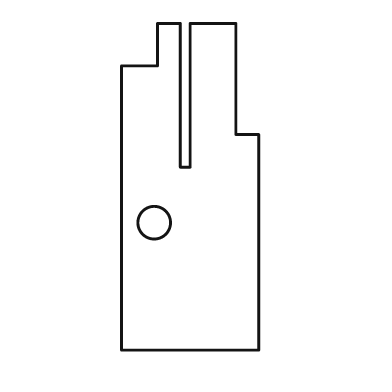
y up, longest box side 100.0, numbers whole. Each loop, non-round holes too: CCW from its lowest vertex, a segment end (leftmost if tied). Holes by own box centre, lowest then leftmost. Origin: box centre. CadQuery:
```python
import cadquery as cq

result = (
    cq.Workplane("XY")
    .moveTo(-21.0, -50.0)
    .lineTo(21.0, -50.0)
    .lineTo(21.0, 16.0)
    .lineTo(14.0, 16.0)
    .lineTo(14.0, 50.0)
    .lineTo(0.0, 50.0)
    .lineTo(0.0, 6.0)
    .lineTo(-3.0, 6.0)
    .lineTo(-3.0, 50.0)
    .lineTo(-10.0, 50.0)
    .lineTo(-10.0, 37.0)
    .lineTo(-21.0, 37.0)
    .close()
    .moveTo(-11.0, -11.0)
    .circle(5.0)
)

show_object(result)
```